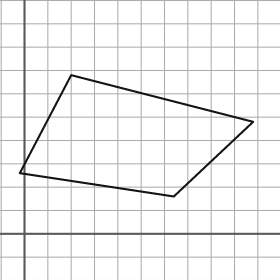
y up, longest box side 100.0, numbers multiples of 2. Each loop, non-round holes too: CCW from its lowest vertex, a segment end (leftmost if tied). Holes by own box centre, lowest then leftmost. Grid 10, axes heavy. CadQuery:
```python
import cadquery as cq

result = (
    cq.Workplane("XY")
    .moveTo(64.0, 16.0)
    .lineTo(98.0, 48.0)
    .lineTo(20.0, 68.0)
    .lineTo(-2.0, 26.0)
    .close()
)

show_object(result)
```